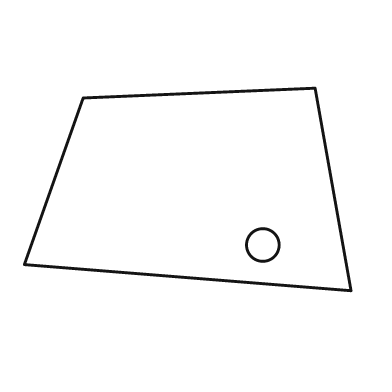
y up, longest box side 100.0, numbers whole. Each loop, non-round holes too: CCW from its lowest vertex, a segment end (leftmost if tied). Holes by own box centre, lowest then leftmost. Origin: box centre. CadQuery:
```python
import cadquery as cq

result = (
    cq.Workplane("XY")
    .moveTo(50.0, -31.0)
    .lineTo(39.0, 31.0)
    .lineTo(-32.0, 28.0)
    .lineTo(-50.0, -23.0)
    .close()
    .moveTo(23.0, -17.0)
    .circle(5.0)
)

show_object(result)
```